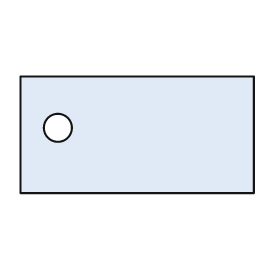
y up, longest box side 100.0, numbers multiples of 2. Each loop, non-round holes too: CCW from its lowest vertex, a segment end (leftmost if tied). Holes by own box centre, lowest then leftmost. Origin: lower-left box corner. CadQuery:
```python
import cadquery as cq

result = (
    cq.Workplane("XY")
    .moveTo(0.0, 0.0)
    .lineTo(100.0, 0.0)
    .lineTo(100.0, 50.0)
    .lineTo(0.0, 50.0)
    .close()
    .moveTo(16.0, 28.0)
    .circle(6.0)
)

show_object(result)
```